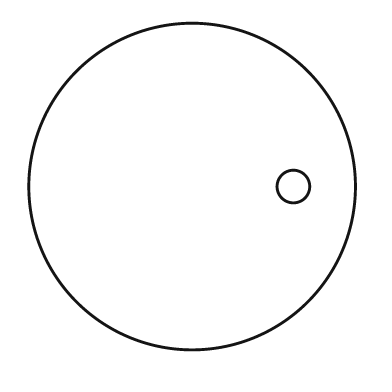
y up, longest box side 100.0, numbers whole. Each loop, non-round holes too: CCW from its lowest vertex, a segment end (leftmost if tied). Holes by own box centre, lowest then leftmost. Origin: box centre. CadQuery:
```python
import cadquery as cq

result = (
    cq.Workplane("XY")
    .moveTo(0.0, 0.0)
    .circle(50.0)
    .moveTo(31.0, 0.0)
    .circle(5.0)
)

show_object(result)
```